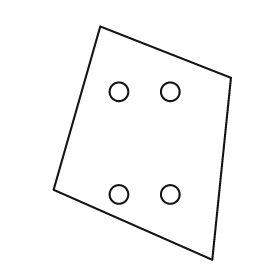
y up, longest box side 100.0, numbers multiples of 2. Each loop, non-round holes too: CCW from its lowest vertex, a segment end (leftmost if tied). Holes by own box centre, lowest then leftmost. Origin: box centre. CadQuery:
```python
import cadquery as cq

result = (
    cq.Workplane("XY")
    .moveTo(30.0, -50.0)
    .lineTo(38.0, 28.0)
    .lineTo(-18.0, 50.0)
    .lineTo(-38.0, -20.0)
    .close()
    .moveTo(-10.0, -22.0)
    .circle(4.0)
    .moveTo(12.0, -22.0)
    .circle(4.0)
    .moveTo(-10.0, 22.0)
    .circle(4.0)
    .moveTo(12.0, 22.0)
    .circle(4.0)
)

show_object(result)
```